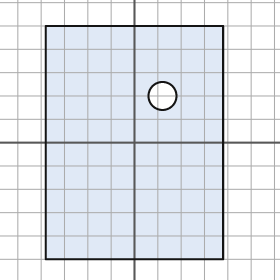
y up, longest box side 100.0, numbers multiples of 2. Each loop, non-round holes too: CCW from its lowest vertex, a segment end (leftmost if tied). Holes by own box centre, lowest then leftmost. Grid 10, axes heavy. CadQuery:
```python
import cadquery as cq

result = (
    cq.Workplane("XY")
    .moveTo(-38.0, -50.0)
    .lineTo(38.0, -50.0)
    .lineTo(38.0, 50.0)
    .lineTo(-38.0, 50.0)
    .close()
    .moveTo(12.0, 20.0)
    .circle(6.0)
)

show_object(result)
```